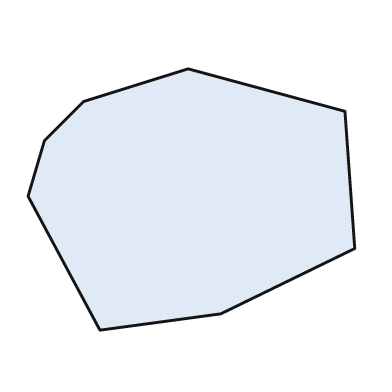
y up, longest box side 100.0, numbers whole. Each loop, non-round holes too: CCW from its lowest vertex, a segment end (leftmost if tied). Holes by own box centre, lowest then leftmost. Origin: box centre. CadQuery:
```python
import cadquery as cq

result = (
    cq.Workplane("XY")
    .moveTo(-28.0, -40.0)
    .lineTo(9.0, -35.0)
    .lineTo(50.0, -15.0)
    .lineTo(47.0, 27.0)
    .lineTo(-1.0, 40.0)
    .lineTo(-33.0, 30.0)
    .lineTo(-45.0, 18.0)
    .lineTo(-50.0, 1.0)
    .close()
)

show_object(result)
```